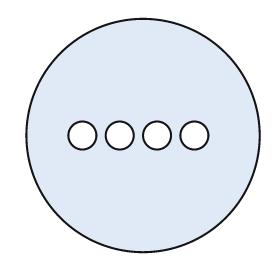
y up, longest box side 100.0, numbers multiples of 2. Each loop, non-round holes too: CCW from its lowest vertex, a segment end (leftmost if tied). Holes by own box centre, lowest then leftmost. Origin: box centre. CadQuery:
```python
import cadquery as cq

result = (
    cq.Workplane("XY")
    .moveTo(0.0, 0.0)
    .circle(50.0)
    .moveTo(-26.0, 0.0)
    .circle(6.0)
    .moveTo(-10.0, 0.0)
    .circle(6.0)
    .moveTo(6.0, 0.0)
    .circle(6.0)
    .moveTo(22.0, 0.0)
    .circle(6.0)
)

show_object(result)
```